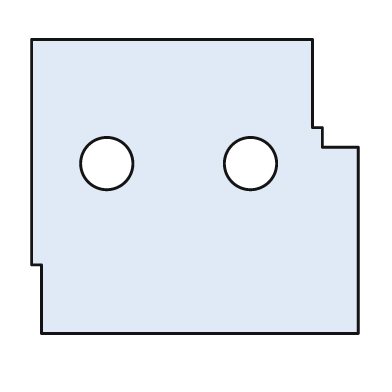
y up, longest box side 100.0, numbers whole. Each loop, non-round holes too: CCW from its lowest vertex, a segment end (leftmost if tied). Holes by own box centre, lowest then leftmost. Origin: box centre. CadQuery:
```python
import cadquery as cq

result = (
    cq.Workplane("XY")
    .moveTo(-47.0, -45.0)
    .lineTo(50.0, -45.0)
    .lineTo(50.0, 12.0)
    .lineTo(39.0, 12.0)
    .lineTo(39.0, 18.0)
    .lineTo(36.0, 18.0)
    .lineTo(36.0, 45.0)
    .lineTo(-50.0, 45.0)
    .lineTo(-50.0, -24.0)
    .lineTo(-47.0, -24.0)
    .close()
    .moveTo(-27.0, 7.0)
    .circle(8.0)
    .moveTo(17.0, 7.0)
    .circle(8.0)
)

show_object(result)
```